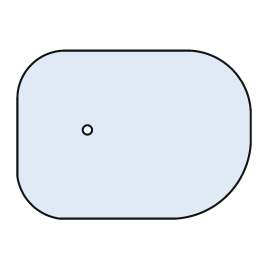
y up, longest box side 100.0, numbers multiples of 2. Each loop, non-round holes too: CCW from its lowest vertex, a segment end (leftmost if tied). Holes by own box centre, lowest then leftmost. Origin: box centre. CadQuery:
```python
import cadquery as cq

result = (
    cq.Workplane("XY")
    .moveTo(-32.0, -36.0)
    .lineTo(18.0, -36.0)
    .threePointArc((40.0, -26.0), (50.0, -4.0))
    .lineTo(50.0, 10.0)
    .threePointArc((42.0, 28.0), (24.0, 36.0))
    .lineTo(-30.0, 36.0)
    .threePointArc((-44.0, 30.0), (-50.0, 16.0))
    .lineTo(-50.0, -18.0)
    .threePointArc((-44.0, -30.0), (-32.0, -36.0))
    .close()
    .moveTo(-20.0, 2.0)
    .circle(2.0)
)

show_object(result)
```